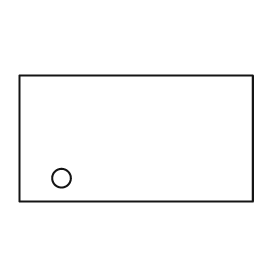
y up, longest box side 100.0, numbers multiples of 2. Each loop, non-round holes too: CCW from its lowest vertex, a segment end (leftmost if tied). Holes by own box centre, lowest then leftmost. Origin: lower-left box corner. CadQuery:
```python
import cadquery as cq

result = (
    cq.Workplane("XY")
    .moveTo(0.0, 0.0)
    .lineTo(100.0, 0.0)
    .lineTo(100.0, 54.0)
    .lineTo(0.0, 54.0)
    .close()
    .moveTo(18.0, 10.0)
    .circle(4.0)
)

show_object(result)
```